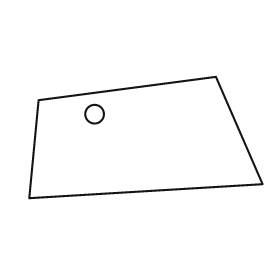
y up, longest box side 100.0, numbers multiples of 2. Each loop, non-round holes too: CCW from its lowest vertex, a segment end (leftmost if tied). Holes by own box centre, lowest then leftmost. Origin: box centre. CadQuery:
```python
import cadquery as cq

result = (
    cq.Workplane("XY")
    .moveTo(-50.0, -26.0)
    .lineTo(50.0, -20.0)
    .lineTo(30.0, 26.0)
    .lineTo(-46.0, 16.0)
    .close()
    .moveTo(-22.0, 10.0)
    .circle(4.0)
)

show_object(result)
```